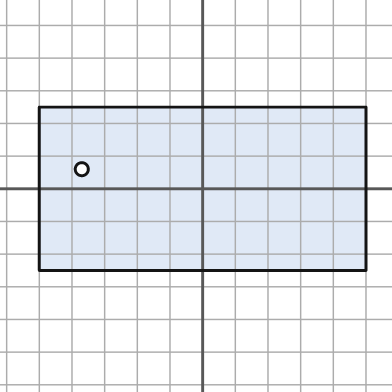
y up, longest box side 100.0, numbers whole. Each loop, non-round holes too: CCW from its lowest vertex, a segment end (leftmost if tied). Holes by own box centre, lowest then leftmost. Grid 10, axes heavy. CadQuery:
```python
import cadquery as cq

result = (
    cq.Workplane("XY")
    .moveTo(-50.0, -25.0)
    .lineTo(50.0, -25.0)
    .lineTo(50.0, 25.0)
    .lineTo(-50.0, 25.0)
    .close()
    .moveTo(-37.0, 6.0)
    .circle(2.0)
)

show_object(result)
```